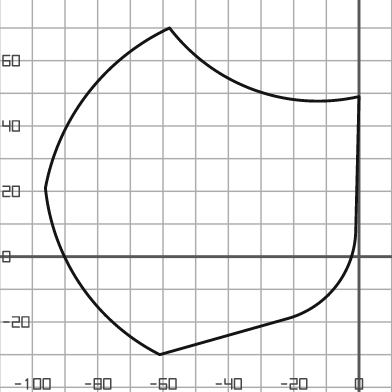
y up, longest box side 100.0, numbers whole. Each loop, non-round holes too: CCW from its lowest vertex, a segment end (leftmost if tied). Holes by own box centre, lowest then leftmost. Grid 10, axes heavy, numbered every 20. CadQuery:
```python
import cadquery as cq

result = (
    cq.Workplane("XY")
    .moveTo(-61.0, -30.0)
    .lineTo(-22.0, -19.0)
    .threePointArc((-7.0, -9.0), (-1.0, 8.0))
    .lineTo(0.0, 49.0)
    .threePointArc((-32.0, 51.0), (-58.0, 70.0))
    .threePointArc((-83.0, 50.0), (-96.0, 21.0))
    .threePointArc((-85.0, -9.0), (-61.0, -30.0))
    .close()
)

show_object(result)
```